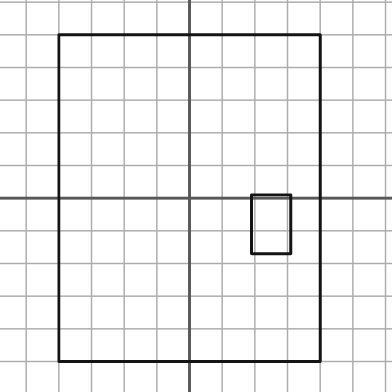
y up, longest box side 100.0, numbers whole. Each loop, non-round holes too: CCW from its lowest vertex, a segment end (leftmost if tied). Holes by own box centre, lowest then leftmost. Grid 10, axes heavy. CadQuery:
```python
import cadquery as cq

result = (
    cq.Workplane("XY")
    .moveTo(-40.0, -50.0)
    .lineTo(40.0, -50.0)
    .lineTo(40.0, 50.0)
    .lineTo(-40.0, 50.0)
    .close()
    .moveTo(19.0, -17.0)
    .lineTo(31.0, -17.0)
    .lineTo(31.0, 1.0)
    .lineTo(19.0, 1.0)
    .close()
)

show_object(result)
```